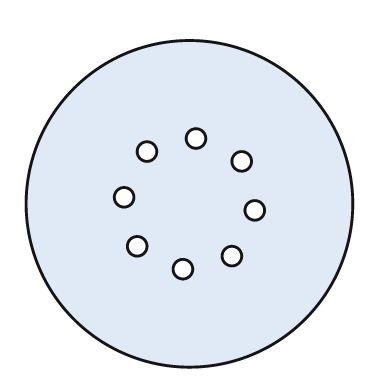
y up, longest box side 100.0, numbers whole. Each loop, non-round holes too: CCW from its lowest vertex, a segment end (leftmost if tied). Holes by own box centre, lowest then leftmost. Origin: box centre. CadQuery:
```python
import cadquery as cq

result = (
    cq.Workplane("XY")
    .moveTo(0.0, 0.0)
    .circle(50.0)
    .moveTo(-2.0, -20.0)
    .circle(3.0)
    .moveTo(13.0, -16.0)
    .circle(3.0)
    .moveTo(-16.0, -13.0)
    .circle(3.0)
    .moveTo(20.0, -2.0)
    .circle(3.0)
    .moveTo(-20.0, 2.0)
    .circle(3.0)
    .moveTo(16.0, 13.0)
    .circle(3.0)
    .moveTo(-13.0, 16.0)
    .circle(3.0)
    .moveTo(2.0, 20.0)
    .circle(3.0)
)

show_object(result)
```